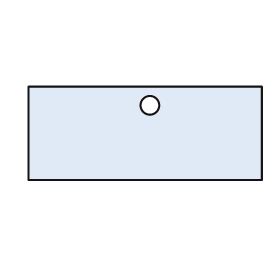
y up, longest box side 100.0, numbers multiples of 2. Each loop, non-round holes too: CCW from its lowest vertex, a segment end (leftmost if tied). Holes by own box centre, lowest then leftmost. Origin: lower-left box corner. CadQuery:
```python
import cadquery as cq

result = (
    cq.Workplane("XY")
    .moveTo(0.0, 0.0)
    .lineTo(100.0, 0.0)
    .lineTo(100.0, 40.0)
    .lineTo(0.0, 40.0)
    .close()
    .moveTo(52.0, 32.0)
    .circle(4.0)
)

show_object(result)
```